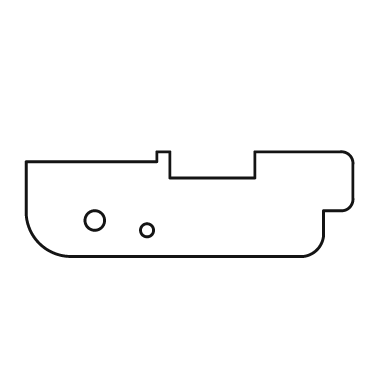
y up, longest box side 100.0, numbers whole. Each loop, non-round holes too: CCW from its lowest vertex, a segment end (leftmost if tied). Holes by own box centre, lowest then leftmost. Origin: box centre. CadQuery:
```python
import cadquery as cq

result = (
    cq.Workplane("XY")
    .moveTo(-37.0, -16.0)
    .lineTo(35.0, -16.0)
    .threePointArc((39.0, -14.0), (41.0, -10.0))
    .lineTo(41.0, -2.0)
    .lineTo(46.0, -2.0)
    .threePointArc((49.0, -1.0), (50.0, 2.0))
    .lineTo(50.0, 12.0)
    .threePointArc((49.0, 15.0), (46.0, 16.0))
    .lineTo(20.0, 16.0)
    .lineTo(20.0, 8.0)
    .lineTo(-6.0, 8.0)
    .lineTo(-6.0, 16.0)
    .lineTo(-10.0, 16.0)
    .lineTo(-10.0, 13.0)
    .lineTo(-50.0, 13.0)
    .lineTo(-50.0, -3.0)
    .threePointArc((-46.0, -12.0), (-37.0, -16.0))
    .close()
    .moveTo(-13.0, -8.0)
    .circle(2.0)
    .moveTo(-29.0, -5.0)
    .circle(3.0)
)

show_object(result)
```